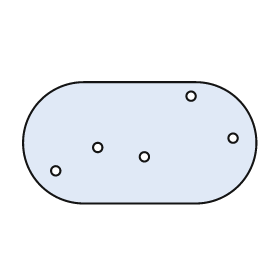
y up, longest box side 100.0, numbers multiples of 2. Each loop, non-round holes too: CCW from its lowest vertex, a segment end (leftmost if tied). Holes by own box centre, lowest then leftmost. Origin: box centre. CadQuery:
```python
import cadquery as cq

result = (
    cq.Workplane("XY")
    .moveTo(-24.0, -26.0)
    .lineTo(24.0, -26.0)
    .threePointArc((50.0, 0.0), (24.0, 26.0))
    .lineTo(-24.0, 26.0)
    .threePointArc((-50.0, 0.0), (-24.0, -26.0))
    .close()
    .moveTo(-36.0, -12.0)
    .circle(2.0)
    .moveTo(2.0, -6.0)
    .circle(2.0)
    .moveTo(-18.0, -2.0)
    .circle(2.0)
    .moveTo(40.0, 2.0)
    .circle(2.0)
    .moveTo(22.0, 20.0)
    .circle(2.0)
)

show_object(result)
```